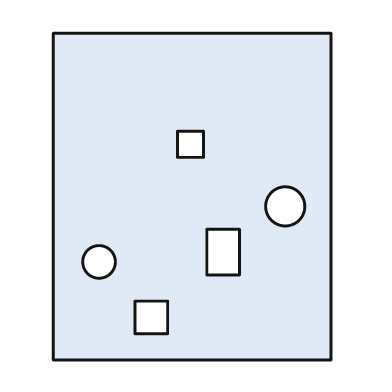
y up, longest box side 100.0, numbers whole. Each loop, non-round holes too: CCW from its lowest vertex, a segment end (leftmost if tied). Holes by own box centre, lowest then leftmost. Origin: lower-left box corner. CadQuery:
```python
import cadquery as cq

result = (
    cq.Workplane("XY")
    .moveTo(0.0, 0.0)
    .lineTo(85.0, 0.0)
    .lineTo(85.0, 100.0)
    .lineTo(0.0, 100.0)
    .close()
    .moveTo(25.0, 8.0)
    .lineTo(35.0, 8.0)
    .lineTo(35.0, 18.0)
    .lineTo(25.0, 18.0)
    .close()
    .moveTo(14.0, 30.0)
    .circle(5.0)
    .moveTo(47.0, 26.0)
    .lineTo(57.0, 26.0)
    .lineTo(57.0, 40.0)
    .lineTo(47.0, 40.0)
    .close()
    .moveTo(71.0, 47.0)
    .circle(6.0)
    .moveTo(38.0, 62.0)
    .lineTo(46.0, 62.0)
    .lineTo(46.0, 70.0)
    .lineTo(38.0, 70.0)
    .close()
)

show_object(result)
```